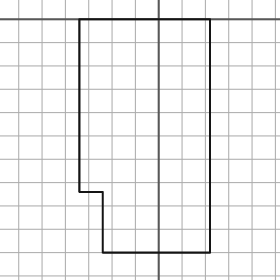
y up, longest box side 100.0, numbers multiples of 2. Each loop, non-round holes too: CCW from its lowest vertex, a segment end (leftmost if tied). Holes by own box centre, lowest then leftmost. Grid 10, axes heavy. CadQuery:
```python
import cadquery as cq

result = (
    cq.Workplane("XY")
    .moveTo(-24.0, -100.0)
    .lineTo(22.0, -100.0)
    .lineTo(22.0, 0.0)
    .lineTo(-34.0, 0.0)
    .lineTo(-34.0, -74.0)
    .lineTo(-24.0, -74.0)
    .close()
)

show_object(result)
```